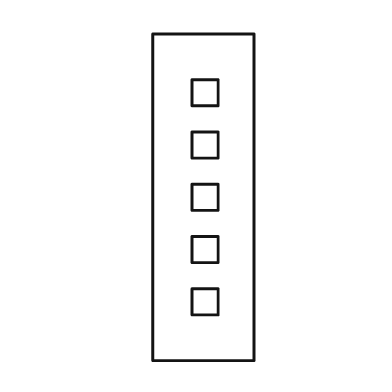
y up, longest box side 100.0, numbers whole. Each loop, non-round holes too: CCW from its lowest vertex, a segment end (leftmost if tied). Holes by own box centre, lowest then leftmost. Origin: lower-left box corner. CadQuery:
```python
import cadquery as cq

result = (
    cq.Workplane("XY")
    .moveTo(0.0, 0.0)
    .lineTo(31.0, 0.0)
    .lineTo(31.0, 100.0)
    .lineTo(0.0, 100.0)
    .close()
    .moveTo(12.0, 14.0)
    .lineTo(20.0, 14.0)
    .lineTo(20.0, 22.0)
    .lineTo(12.0, 22.0)
    .close()
    .moveTo(12.0, 30.0)
    .lineTo(20.0, 30.0)
    .lineTo(20.0, 38.0)
    .lineTo(12.0, 38.0)
    .close()
    .moveTo(12.0, 46.0)
    .lineTo(20.0, 46.0)
    .lineTo(20.0, 54.0)
    .lineTo(12.0, 54.0)
    .close()
    .moveTo(12.0, 62.0)
    .lineTo(20.0, 62.0)
    .lineTo(20.0, 70.0)
    .lineTo(12.0, 70.0)
    .close()
    .moveTo(12.0, 78.0)
    .lineTo(20.0, 78.0)
    .lineTo(20.0, 86.0)
    .lineTo(12.0, 86.0)
    .close()
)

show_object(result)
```